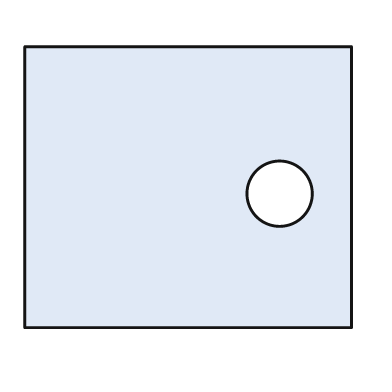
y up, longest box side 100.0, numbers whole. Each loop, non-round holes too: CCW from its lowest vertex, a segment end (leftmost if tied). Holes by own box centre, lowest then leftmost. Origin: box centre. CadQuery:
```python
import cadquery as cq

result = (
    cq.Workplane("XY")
    .moveTo(-50.0, -43.0)
    .lineTo(50.0, -43.0)
    .lineTo(50.0, 43.0)
    .lineTo(-50.0, 43.0)
    .close()
    .moveTo(28.0, -2.0)
    .circle(10.0)
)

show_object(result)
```